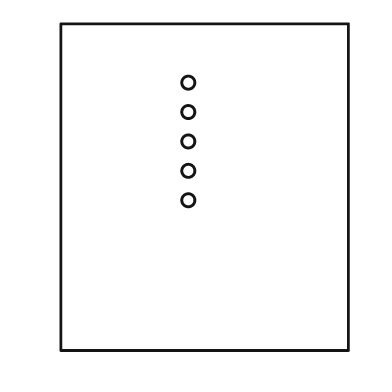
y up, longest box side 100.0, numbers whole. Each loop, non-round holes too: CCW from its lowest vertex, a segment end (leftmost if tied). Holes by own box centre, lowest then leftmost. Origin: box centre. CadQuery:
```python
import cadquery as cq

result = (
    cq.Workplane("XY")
    .moveTo(-44.0, -50.0)
    .lineTo(44.0, -50.0)
    .lineTo(44.0, 50.0)
    .lineTo(-44.0, 50.0)
    .close()
    .moveTo(-5.0, -4.0)
    .circle(2.0)
    .moveTo(-5.0, 5.0)
    .circle(2.0)
    .moveTo(-5.0, 14.0)
    .circle(2.0)
    .moveTo(-5.0, 23.0)
    .circle(2.0)
    .moveTo(-5.0, 32.0)
    .circle(2.0)
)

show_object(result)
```